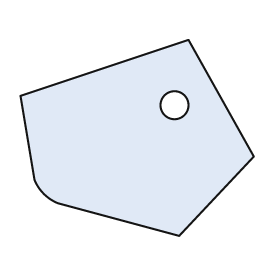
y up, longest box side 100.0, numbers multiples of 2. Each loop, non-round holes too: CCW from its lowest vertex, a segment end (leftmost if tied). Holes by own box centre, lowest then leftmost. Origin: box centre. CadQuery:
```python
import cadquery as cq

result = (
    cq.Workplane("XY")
    .moveTo(18.0, -42.0)
    .lineTo(50.0, -8.0)
    .lineTo(22.0, 42.0)
    .lineTo(-50.0, 18.0)
    .lineTo(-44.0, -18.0)
    .threePointArc((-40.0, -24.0), (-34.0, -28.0))
    .close()
    .moveTo(16.0, 14.0)
    .circle(6.0)
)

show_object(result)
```